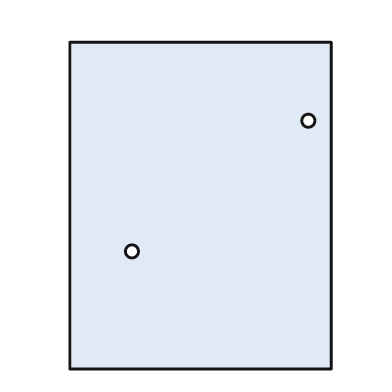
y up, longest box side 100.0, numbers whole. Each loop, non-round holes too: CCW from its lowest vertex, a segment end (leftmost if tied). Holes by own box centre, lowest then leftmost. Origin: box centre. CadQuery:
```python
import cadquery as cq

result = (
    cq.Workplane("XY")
    .moveTo(-40.0, -50.0)
    .lineTo(40.0, -50.0)
    .lineTo(40.0, 50.0)
    .lineTo(-40.0, 50.0)
    .close()
    .moveTo(-21.0, -14.0)
    .circle(2.0)
    .moveTo(33.0, 26.0)
    .circle(2.0)
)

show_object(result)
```